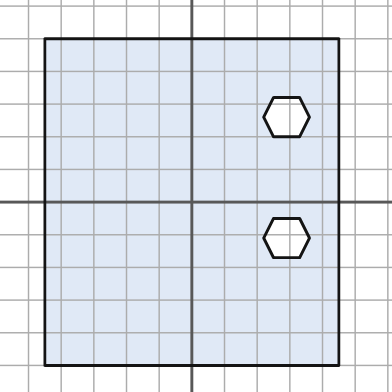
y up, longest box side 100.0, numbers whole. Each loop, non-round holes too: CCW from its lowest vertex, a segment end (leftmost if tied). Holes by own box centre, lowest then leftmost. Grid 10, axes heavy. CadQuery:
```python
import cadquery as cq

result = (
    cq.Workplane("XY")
    .moveTo(-45.0, -50.0)
    .lineTo(45.0, -50.0)
    .lineTo(45.0, 50.0)
    .lineTo(-45.0, 50.0)
    .close()
    .moveTo(25.0, -17.0)
    .lineTo(33.0, -17.0)
    .lineTo(36.0, -11.0)
    .lineTo(33.0, -5.0)
    .lineTo(25.0, -5.0)
    .lineTo(22.0, -11.0)
    .close()
    .moveTo(25.0, 20.0)
    .lineTo(33.0, 20.0)
    .lineTo(36.0, 26.0)
    .lineTo(33.0, 32.0)
    .lineTo(25.0, 32.0)
    .lineTo(22.0, 26.0)
    .close()
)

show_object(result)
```